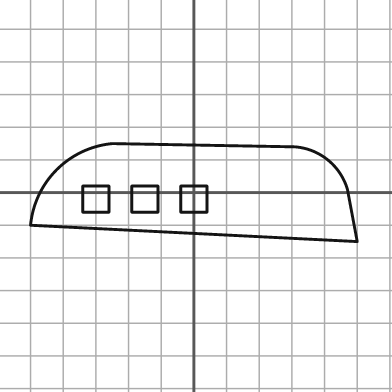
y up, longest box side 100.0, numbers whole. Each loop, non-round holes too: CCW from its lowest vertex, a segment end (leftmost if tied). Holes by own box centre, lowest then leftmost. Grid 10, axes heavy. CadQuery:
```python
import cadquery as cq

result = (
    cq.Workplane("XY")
    .moveTo(50.0, -15.0)
    .lineTo(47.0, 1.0)
    .threePointArc((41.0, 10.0), (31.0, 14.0))
    .lineTo(-25.0, 15.0)
    .threePointArc((-42.0, 7.0), (-50.0, -10.0))
    .close()
    .moveTo(-34.0, -6.0)
    .lineTo(-26.0, -6.0)
    .lineTo(-26.0, 2.0)
    .lineTo(-34.0, 2.0)
    .close()
    .moveTo(-19.0, -6.0)
    .lineTo(-11.0, -6.0)
    .lineTo(-11.0, 2.0)
    .lineTo(-19.0, 2.0)
    .close()
    .moveTo(-4.0, -6.0)
    .lineTo(4.0, -6.0)
    .lineTo(4.0, 2.0)
    .lineTo(-4.0, 2.0)
    .close()
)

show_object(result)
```